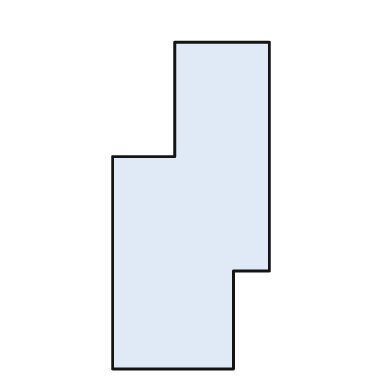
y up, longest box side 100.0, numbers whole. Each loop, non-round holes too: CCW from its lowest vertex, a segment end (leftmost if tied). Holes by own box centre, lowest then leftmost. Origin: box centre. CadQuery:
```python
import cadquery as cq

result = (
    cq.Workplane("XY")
    .moveTo(-24.0, -50.0)
    .lineTo(13.0, -50.0)
    .lineTo(13.0, -20.0)
    .lineTo(24.0, -20.0)
    .lineTo(24.0, 50.0)
    .lineTo(-5.0, 50.0)
    .lineTo(-5.0, 15.0)
    .lineTo(-24.0, 15.0)
    .close()
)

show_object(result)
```